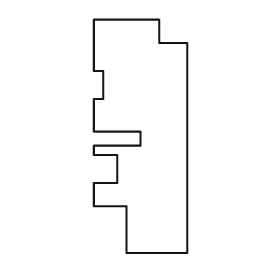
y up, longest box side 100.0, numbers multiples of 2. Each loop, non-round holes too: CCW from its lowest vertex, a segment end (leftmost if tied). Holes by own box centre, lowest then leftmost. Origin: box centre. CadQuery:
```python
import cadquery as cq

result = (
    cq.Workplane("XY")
    .moveTo(-6.0, -50.0)
    .lineTo(20.0, -50.0)
    .lineTo(20.0, 40.0)
    .lineTo(8.0, 40.0)
    .lineTo(8.0, 50.0)
    .lineTo(-20.0, 50.0)
    .lineTo(-20.0, 28.0)
    .lineTo(-16.0, 28.0)
    .lineTo(-16.0, 16.0)
    .lineTo(-20.0, 16.0)
    .lineTo(-20.0, 2.0)
    .lineTo(0.0, 2.0)
    .lineTo(0.0, -4.0)
    .lineTo(-20.0, -4.0)
    .lineTo(-20.0, -8.0)
    .lineTo(-10.0, -8.0)
    .lineTo(-10.0, -20.0)
    .lineTo(-20.0, -20.0)
    .lineTo(-20.0, -30.0)
    .lineTo(-6.0, -30.0)
    .close()
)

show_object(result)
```